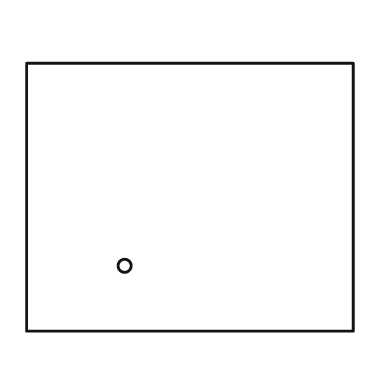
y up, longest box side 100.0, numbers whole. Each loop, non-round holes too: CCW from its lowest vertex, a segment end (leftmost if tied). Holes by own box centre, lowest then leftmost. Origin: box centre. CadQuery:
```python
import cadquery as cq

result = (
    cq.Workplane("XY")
    .moveTo(-50.0, -41.0)
    .lineTo(50.0, -41.0)
    .lineTo(50.0, 41.0)
    .lineTo(-50.0, 41.0)
    .close()
    .moveTo(-20.0, -21.0)
    .circle(2.0)
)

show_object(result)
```